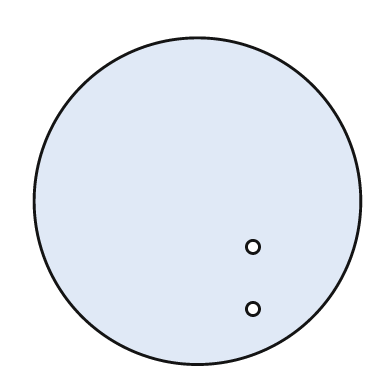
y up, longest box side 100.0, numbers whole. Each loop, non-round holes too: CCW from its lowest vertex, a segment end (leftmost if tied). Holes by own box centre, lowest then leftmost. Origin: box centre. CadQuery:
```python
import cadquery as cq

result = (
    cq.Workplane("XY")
    .moveTo(0.0, 0.0)
    .circle(50.0)
    .moveTo(17.0, -33.0)
    .circle(2.0)
    .moveTo(17.0, -14.0)
    .circle(2.0)
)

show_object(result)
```